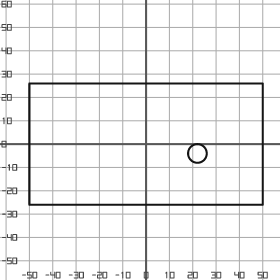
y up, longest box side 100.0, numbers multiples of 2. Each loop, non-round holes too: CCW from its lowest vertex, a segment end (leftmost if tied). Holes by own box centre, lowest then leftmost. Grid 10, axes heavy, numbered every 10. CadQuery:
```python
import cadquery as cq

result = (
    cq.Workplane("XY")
    .moveTo(-50.0, -26.0)
    .lineTo(50.0, -26.0)
    .lineTo(50.0, 26.0)
    .lineTo(-50.0, 26.0)
    .close()
    .moveTo(22.0, -4.0)
    .circle(4.0)
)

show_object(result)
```